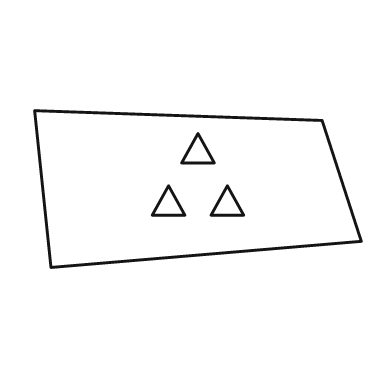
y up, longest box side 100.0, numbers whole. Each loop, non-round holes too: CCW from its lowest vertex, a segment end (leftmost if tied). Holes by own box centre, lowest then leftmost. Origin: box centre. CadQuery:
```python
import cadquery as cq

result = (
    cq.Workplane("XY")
    .moveTo(-45.0, -24.0)
    .lineTo(50.0, -16.0)
    .lineTo(38.0, 21.0)
    .lineTo(-50.0, 24.0)
    .close()
    .moveTo(-14.0, -8.0)
    .lineTo(-4.0, -8.0)
    .lineTo(-9.0, 1.0)
    .close()
    .moveTo(4.0, -8.0)
    .lineTo(14.0, -8.0)
    .lineTo(9.0, 1.0)
    .close()
    .moveTo(-5.0, 8.0)
    .lineTo(5.0, 8.0)
    .lineTo(0.0, 17.0)
    .close()
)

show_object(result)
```